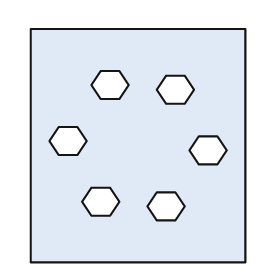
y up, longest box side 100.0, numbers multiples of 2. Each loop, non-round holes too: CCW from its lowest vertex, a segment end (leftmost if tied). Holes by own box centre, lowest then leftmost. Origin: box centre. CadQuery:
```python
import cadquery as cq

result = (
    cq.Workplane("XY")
    .moveTo(-46.0, -50.0)
    .lineTo(46.0, -50.0)
    .lineTo(46.0, 50.0)
    .lineTo(-46.0, 50.0)
    .close()
    .moveTo(8.0, -32.0)
    .lineTo(16.0, -32.0)
    .lineTo(20.0, -26.0)
    .lineTo(16.0, -20.0)
    .lineTo(8.0, -20.0)
    .lineTo(4.0, -26.0)
    .close()
    .moveTo(-20.0, -30.0)
    .lineTo(-12.0, -30.0)
    .lineTo(-8.0, -24.0)
    .lineTo(-12.0, -18.0)
    .lineTo(-20.0, -18.0)
    .lineTo(-24.0, -24.0)
    .close()
    .moveTo(26.0, -8.0)
    .lineTo(34.0, -8.0)
    .lineTo(38.0, -2.0)
    .lineTo(34.0, 4.0)
    .lineTo(26.0, 4.0)
    .lineTo(22.0, -2.0)
    .close()
    .moveTo(-34.0, -4.0)
    .lineTo(-26.0, -4.0)
    .lineTo(-22.0, 2.0)
    .lineTo(-26.0, 8.0)
    .lineTo(-34.0, 8.0)
    .lineTo(-38.0, 2.0)
    .close()
    .moveTo(12.0, 18.0)
    .lineTo(20.0, 18.0)
    .lineTo(24.0, 24.0)
    .lineTo(20.0, 30.0)
    .lineTo(12.0, 30.0)
    .lineTo(8.0, 24.0)
    .close()
    .moveTo(-16.0, 20.0)
    .lineTo(-8.0, 20.0)
    .lineTo(-4.0, 26.0)
    .lineTo(-8.0, 32.0)
    .lineTo(-16.0, 32.0)
    .lineTo(-20.0, 26.0)
    .close()
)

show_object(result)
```